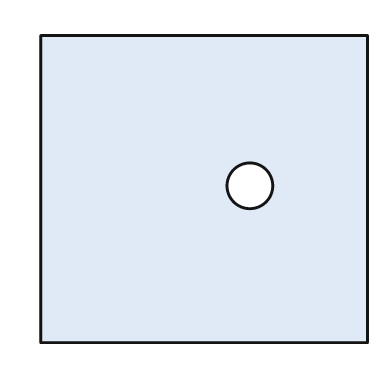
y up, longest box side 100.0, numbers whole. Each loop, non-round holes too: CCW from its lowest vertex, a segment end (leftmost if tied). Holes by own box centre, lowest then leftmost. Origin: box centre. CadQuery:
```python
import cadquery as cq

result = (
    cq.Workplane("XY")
    .moveTo(-50.0, -47.0)
    .lineTo(50.0, -47.0)
    .lineTo(50.0, 47.0)
    .lineTo(-50.0, 47.0)
    .close()
    .moveTo(14.0, 1.0)
    .circle(7.0)
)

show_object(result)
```